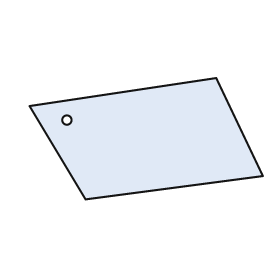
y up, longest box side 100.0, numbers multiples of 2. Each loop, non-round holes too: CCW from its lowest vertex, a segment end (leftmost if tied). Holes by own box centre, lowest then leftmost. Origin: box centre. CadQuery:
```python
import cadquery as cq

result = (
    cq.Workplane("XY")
    .moveTo(-26.0, -26.0)
    .lineTo(50.0, -16.0)
    .lineTo(30.0, 26.0)
    .lineTo(-50.0, 14.0)
    .close()
    .moveTo(-34.0, 8.0)
    .circle(2.0)
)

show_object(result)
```